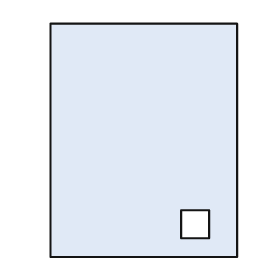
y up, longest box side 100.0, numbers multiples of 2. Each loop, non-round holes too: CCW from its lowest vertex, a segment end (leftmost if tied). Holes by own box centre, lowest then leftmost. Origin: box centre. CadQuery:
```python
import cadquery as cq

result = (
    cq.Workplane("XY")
    .moveTo(-40.0, -50.0)
    .lineTo(40.0, -50.0)
    .lineTo(40.0, 50.0)
    .lineTo(-40.0, 50.0)
    .close()
    .moveTo(16.0, -42.0)
    .lineTo(28.0, -42.0)
    .lineTo(28.0, -30.0)
    .lineTo(16.0, -30.0)
    .close()
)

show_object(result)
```